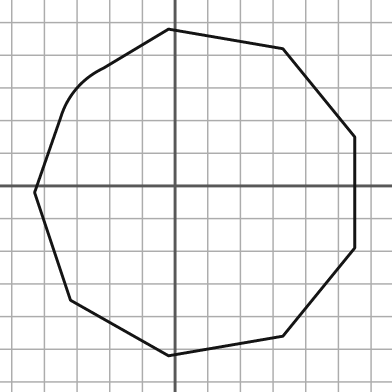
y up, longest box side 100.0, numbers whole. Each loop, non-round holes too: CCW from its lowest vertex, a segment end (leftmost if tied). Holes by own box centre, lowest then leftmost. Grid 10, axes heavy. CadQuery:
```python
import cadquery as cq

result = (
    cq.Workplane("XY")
    .moveTo(-2.0, -52.0)
    .lineTo(33.0, -46.0)
    .lineTo(55.0, -19.0)
    .lineTo(55.0, 15.0)
    .lineTo(33.0, 42.0)
    .lineTo(-2.0, 48.0)
    .lineTo(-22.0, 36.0)
    .threePointArc((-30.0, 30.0), (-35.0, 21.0))
    .lineTo(-43.0, -2.0)
    .lineTo(-32.0, -35.0)
    .close()
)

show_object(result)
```